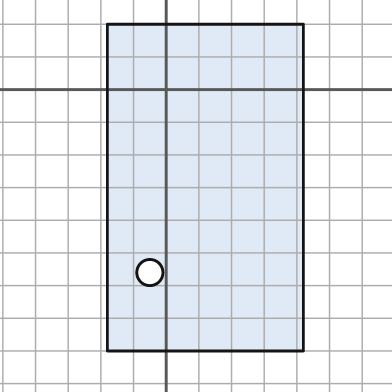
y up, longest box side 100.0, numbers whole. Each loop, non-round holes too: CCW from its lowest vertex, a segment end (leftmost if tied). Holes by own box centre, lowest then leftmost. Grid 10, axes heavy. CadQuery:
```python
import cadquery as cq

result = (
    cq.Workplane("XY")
    .moveTo(-18.0, -80.0)
    .lineTo(42.0, -80.0)
    .lineTo(42.0, 20.0)
    .lineTo(-18.0, 20.0)
    .close()
    .moveTo(-5.0, -56.0)
    .circle(4.0)
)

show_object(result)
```